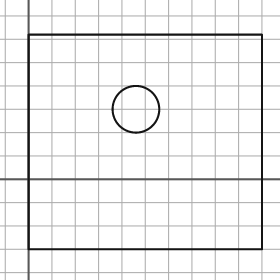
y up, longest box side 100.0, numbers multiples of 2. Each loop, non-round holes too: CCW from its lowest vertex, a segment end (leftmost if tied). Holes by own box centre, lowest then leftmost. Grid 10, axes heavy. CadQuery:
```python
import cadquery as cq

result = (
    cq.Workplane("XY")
    .moveTo(0.0, -30.0)
    .lineTo(100.0, -30.0)
    .lineTo(100.0, 62.0)
    .lineTo(0.0, 62.0)
    .close()
    .moveTo(46.0, 30.0)
    .circle(10.0)
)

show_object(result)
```